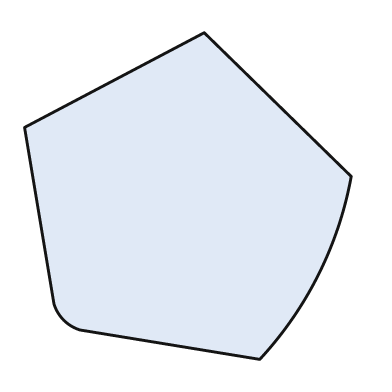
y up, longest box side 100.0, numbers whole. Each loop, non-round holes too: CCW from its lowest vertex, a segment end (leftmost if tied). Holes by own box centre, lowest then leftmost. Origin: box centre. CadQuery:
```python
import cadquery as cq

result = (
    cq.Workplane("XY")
    .moveTo(22.0, -50.0)
    .threePointArc((40.0, -24.0), (50.0, 6.0))
    .lineTo(5.0, 50.0)
    .lineTo(-50.0, 21.0)
    .lineTo(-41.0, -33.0)
    .threePointArc((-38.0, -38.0), (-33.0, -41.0))
    .close()
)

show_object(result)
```